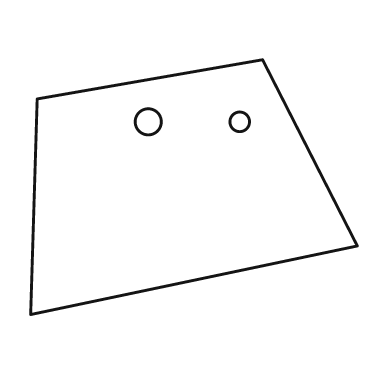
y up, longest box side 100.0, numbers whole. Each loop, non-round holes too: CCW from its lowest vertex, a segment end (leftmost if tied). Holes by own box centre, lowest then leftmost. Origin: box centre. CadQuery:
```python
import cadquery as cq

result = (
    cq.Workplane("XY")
    .moveTo(-50.0, -39.0)
    .lineTo(50.0, -18.0)
    .lineTo(21.0, 39.0)
    .lineTo(-48.0, 27.0)
    .close()
    .moveTo(-14.0, 20.0)
    .circle(4.0)
    .moveTo(14.0, 20.0)
    .circle(3.0)
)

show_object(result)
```